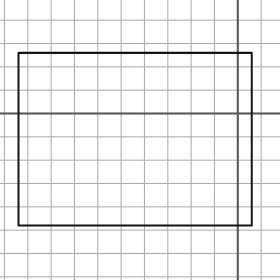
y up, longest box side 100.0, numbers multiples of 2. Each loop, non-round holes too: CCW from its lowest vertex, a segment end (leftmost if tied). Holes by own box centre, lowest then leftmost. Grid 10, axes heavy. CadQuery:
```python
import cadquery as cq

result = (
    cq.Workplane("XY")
    .moveTo(-94.0, -48.0)
    .lineTo(6.0, -48.0)
    .lineTo(6.0, 26.0)
    .lineTo(-94.0, 26.0)
    .close()
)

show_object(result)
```